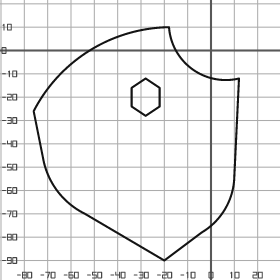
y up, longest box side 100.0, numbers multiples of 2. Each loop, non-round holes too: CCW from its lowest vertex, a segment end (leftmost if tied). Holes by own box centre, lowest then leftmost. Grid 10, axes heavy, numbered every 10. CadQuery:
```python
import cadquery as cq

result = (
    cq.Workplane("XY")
    .moveTo(-20.0, -90.0)
    .lineTo(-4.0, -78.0)
    .threePointArc((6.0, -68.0), (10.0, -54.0))
    .lineTo(12.0, -12.0)
    .threePointArc((-8.0, -8.0), (-18.0, 10.0))
    .threePointArc((-52.0, 0.0), (-76.0, -26.0))
    .lineTo(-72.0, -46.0)
    .threePointArc((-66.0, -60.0), (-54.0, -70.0))
    .close()
    .moveTo(-28.0, -28.0)
    .lineTo(-22.0, -24.0)
    .lineTo(-22.0, -16.0)
    .lineTo(-28.0, -12.0)
    .lineTo(-34.0, -16.0)
    .lineTo(-34.0, -24.0)
    .close()
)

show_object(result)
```